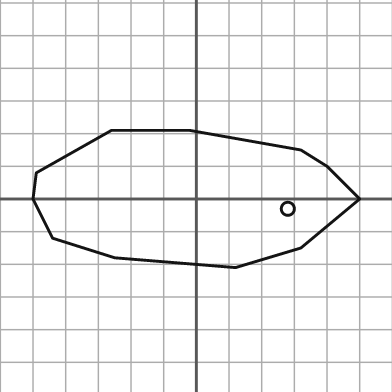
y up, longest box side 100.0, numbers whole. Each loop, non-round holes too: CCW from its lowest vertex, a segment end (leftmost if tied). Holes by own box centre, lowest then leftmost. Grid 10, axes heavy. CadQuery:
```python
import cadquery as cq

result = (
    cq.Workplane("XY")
    .moveTo(12.0, -21.0)
    .lineTo(32.0, -15.0)
    .lineTo(50.0, 0.0)
    .lineTo(40.0, 10.0)
    .lineTo(32.0, 15.0)
    .lineTo(-2.0, 21.0)
    .lineTo(-26.0, 21.0)
    .lineTo(-49.0, 8.0)
    .lineTo(-50.0, 0.0)
    .lineTo(-44.0, -12.0)
    .lineTo(-25.0, -18.0)
    .close()
    .moveTo(28.0, -3.0)
    .circle(2.0)
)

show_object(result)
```